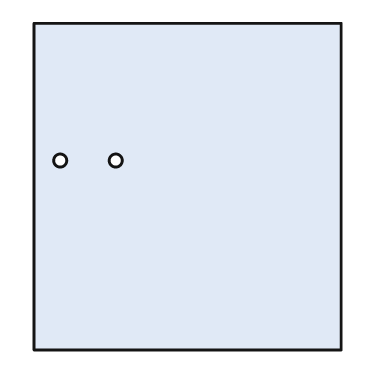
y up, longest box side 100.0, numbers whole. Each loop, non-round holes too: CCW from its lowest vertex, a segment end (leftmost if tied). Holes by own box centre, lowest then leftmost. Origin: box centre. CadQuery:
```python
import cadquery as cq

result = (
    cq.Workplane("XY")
    .moveTo(-47.0, -50.0)
    .lineTo(47.0, -50.0)
    .lineTo(47.0, 50.0)
    .lineTo(-47.0, 50.0)
    .close()
    .moveTo(-39.0, 8.0)
    .circle(2.0)
    .moveTo(-22.0, 8.0)
    .circle(2.0)
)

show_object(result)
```